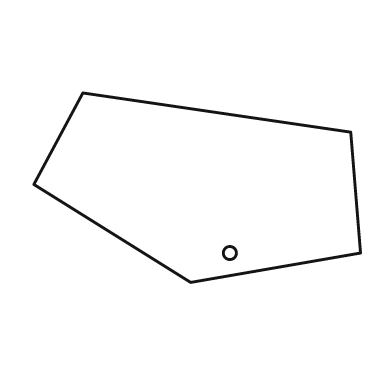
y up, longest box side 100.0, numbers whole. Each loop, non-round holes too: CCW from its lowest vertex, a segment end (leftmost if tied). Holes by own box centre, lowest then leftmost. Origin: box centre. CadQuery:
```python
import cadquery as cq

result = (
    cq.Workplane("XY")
    .moveTo(-2.0, -29.0)
    .lineTo(50.0, -20.0)
    .lineTo(47.0, 17.0)
    .lineTo(-35.0, 29.0)
    .lineTo(-50.0, 1.0)
    .close()
    .moveTo(10.0, -20.0)
    .circle(2.0)
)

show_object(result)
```